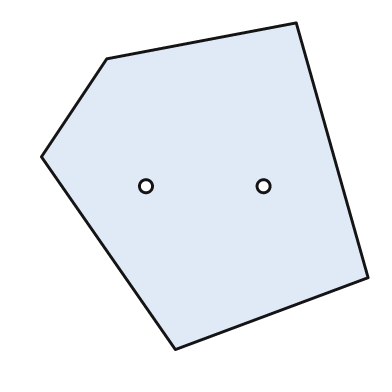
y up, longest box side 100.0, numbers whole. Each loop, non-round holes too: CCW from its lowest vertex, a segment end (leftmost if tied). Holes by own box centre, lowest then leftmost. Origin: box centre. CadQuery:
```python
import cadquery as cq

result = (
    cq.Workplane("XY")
    .moveTo(-9.0, -50.0)
    .lineTo(50.0, -28.0)
    .lineTo(28.0, 50.0)
    .lineTo(-30.0, 39.0)
    .lineTo(-50.0, 9.0)
    .close()
    .moveTo(-18.0, 0.0)
    .circle(2.0)
    .moveTo(18.0, 0.0)
    .circle(2.0)
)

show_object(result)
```